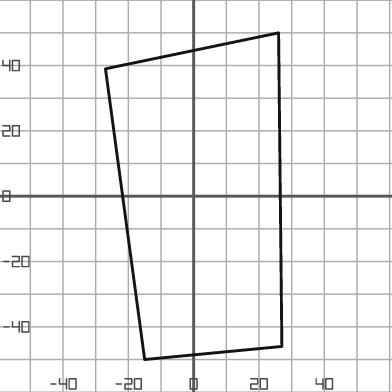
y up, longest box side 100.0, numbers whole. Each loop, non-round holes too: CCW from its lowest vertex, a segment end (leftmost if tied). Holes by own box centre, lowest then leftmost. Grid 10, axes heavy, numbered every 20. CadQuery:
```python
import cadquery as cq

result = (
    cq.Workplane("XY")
    .moveTo(-15.0, -50.0)
    .lineTo(27.0, -46.0)
    .lineTo(26.0, 50.0)
    .lineTo(-27.0, 39.0)
    .close()
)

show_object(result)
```